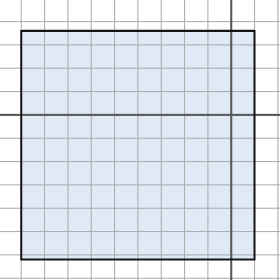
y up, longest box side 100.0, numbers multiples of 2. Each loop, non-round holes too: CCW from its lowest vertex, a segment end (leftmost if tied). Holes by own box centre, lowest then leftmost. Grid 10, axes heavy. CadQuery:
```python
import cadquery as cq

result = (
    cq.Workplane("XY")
    .moveTo(-90.0, -62.0)
    .lineTo(10.0, -62.0)
    .lineTo(10.0, 36.0)
    .lineTo(-90.0, 36.0)
    .close()
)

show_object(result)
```